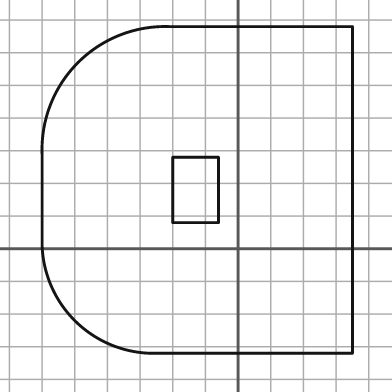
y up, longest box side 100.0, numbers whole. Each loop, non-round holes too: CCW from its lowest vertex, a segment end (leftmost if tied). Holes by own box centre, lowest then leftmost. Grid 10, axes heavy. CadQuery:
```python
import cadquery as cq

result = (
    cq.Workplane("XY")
    .moveTo(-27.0, -32.0)
    .lineTo(35.0, -32.0)
    .lineTo(35.0, 68.0)
    .lineTo(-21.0, 68.0)
    .threePointArc((-49.0, 57.0), (-60.0, 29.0))
    .lineTo(-60.0, 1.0)
    .threePointArc((-50.0, -22.0), (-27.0, -32.0))
    .close()
    .moveTo(-20.0, 8.0)
    .lineTo(-6.0, 8.0)
    .lineTo(-6.0, 28.0)
    .lineTo(-20.0, 28.0)
    .close()
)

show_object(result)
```